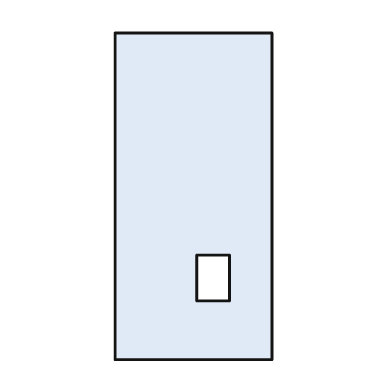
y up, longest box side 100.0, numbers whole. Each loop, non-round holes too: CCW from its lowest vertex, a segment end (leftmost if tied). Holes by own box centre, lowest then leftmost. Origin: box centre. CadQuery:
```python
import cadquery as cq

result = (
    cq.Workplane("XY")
    .moveTo(-24.0, -50.0)
    .lineTo(24.0, -50.0)
    .lineTo(24.0, 50.0)
    .lineTo(-24.0, 50.0)
    .close()
    .moveTo(1.0, -32.0)
    .lineTo(11.0, -32.0)
    .lineTo(11.0, -18.0)
    .lineTo(1.0, -18.0)
    .close()
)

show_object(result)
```